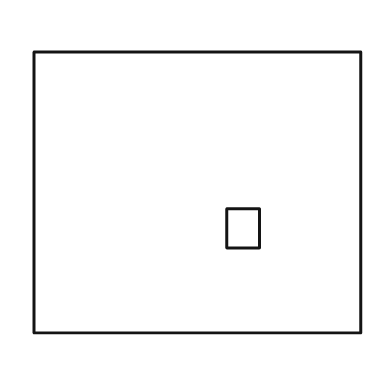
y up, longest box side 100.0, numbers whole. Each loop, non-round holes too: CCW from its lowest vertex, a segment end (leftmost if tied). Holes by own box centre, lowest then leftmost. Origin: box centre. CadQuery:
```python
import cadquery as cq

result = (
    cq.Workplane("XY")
    .moveTo(-50.0, -43.0)
    .lineTo(50.0, -43.0)
    .lineTo(50.0, 43.0)
    .lineTo(-50.0, 43.0)
    .close()
    .moveTo(9.0, -17.0)
    .lineTo(19.0, -17.0)
    .lineTo(19.0, -5.0)
    .lineTo(9.0, -5.0)
    .close()
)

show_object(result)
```